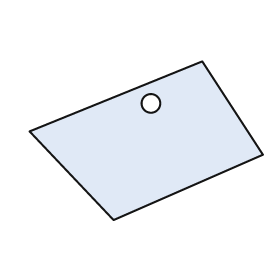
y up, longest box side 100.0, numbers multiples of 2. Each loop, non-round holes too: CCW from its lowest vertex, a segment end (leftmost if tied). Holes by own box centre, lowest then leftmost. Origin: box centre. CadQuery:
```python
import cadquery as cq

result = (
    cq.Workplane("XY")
    .moveTo(-14.0, -34.0)
    .lineTo(50.0, -6.0)
    .lineTo(24.0, 34.0)
    .lineTo(-50.0, 4.0)
    .close()
    .moveTo(2.0, 16.0)
    .circle(4.0)
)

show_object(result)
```